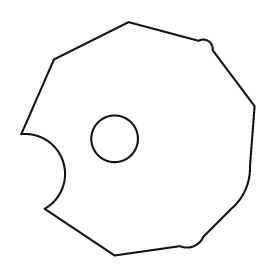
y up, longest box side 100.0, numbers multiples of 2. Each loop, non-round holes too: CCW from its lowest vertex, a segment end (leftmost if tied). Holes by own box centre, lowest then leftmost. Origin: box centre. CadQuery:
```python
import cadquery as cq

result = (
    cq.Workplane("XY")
    .moveTo(-10.0, -50.0)
    .lineTo(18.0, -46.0)
    .threePointArc((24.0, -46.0), (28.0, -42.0))
    .lineTo(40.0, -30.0)
    .threePointArc((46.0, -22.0), (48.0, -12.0))
    .lineTo(50.0, 14.0)
    .lineTo(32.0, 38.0)
    .threePointArc((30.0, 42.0), (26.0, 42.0))
    .lineTo(-4.0, 50.0)
    .lineTo(-36.0, 34.0)
    .lineTo(-50.0, 2.0)
    .threePointArc((-32.0, -10.0), (-40.0, -30.0))
    .close()
    .moveTo(-10.0, 0.0)
    .circle(10.0)
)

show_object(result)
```